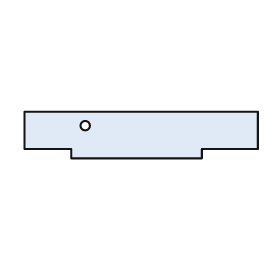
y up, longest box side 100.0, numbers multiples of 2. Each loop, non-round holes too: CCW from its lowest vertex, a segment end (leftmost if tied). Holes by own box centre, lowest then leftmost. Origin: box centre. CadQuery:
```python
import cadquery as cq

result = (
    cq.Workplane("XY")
    .moveTo(-30.0, -10.0)
    .lineTo(26.0, -10.0)
    .lineTo(26.0, -6.0)
    .lineTo(50.0, -6.0)
    .lineTo(50.0, 10.0)
    .lineTo(-50.0, 10.0)
    .lineTo(-50.0, -6.0)
    .lineTo(-30.0, -6.0)
    .close()
    .moveTo(-24.0, 4.0)
    .circle(2.0)
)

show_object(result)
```